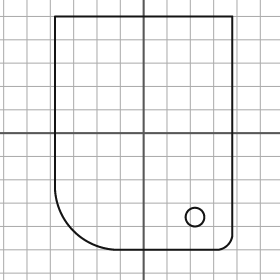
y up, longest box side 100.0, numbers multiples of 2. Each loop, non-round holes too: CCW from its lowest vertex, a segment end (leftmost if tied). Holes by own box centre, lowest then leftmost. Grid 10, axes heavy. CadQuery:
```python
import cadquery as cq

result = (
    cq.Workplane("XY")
    .moveTo(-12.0, -50.0)
    .lineTo(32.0, -50.0)
    .threePointArc((36.0, -48.0), (38.0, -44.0))
    .lineTo(38.0, 50.0)
    .lineTo(-38.0, 50.0)
    .lineTo(-38.0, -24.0)
    .threePointArc((-30.0, -42.0), (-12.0, -50.0))
    .close()
    .moveTo(22.0, -36.0)
    .circle(4.0)
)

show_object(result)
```